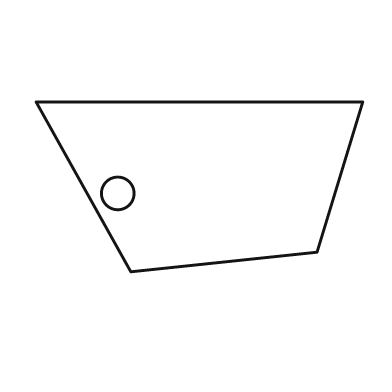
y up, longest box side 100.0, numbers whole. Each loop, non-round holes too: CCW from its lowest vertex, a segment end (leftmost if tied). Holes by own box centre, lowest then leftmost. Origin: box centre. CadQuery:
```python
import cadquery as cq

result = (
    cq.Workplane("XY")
    .moveTo(-21.0, -26.0)
    .lineTo(36.0, -20.0)
    .lineTo(50.0, 26.0)
    .lineTo(-50.0, 26.0)
    .close()
    .moveTo(-25.0, -2.0)
    .circle(5.0)
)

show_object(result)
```